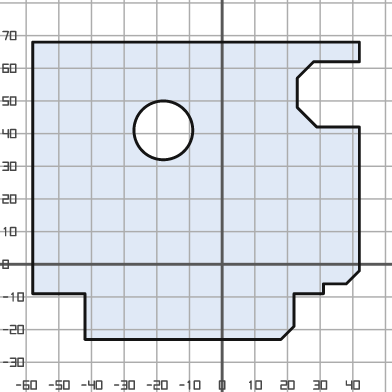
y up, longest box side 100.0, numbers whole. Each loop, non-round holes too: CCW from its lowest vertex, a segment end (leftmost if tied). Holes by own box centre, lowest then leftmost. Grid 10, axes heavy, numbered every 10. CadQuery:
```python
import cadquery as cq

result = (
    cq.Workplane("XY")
    .moveTo(-42.0, -23.0)
    .lineTo(18.0, -23.0)
    .lineTo(22.0, -19.0)
    .lineTo(22.0, -9.0)
    .lineTo(31.0, -9.0)
    .lineTo(31.0, -6.0)
    .lineTo(38.0, -6.0)
    .lineTo(42.0, -2.0)
    .lineTo(42.0, 42.0)
    .lineTo(29.0, 42.0)
    .lineTo(23.0, 48.0)
    .lineTo(23.0, 57.0)
    .lineTo(28.0, 62.0)
    .lineTo(42.0, 62.0)
    .lineTo(42.0, 68.0)
    .lineTo(-58.0, 68.0)
    .lineTo(-58.0, -9.0)
    .lineTo(-42.0, -9.0)
    .close()
    .moveTo(-18.0, 41.0)
    .circle(9.0)
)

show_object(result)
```